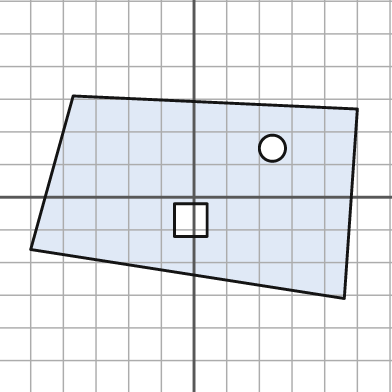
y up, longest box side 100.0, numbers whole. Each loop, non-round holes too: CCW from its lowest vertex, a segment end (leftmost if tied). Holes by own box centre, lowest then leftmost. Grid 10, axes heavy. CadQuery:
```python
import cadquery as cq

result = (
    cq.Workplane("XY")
    .moveTo(46.0, -31.0)
    .lineTo(50.0, 27.0)
    .lineTo(-37.0, 31.0)
    .lineTo(-50.0, -16.0)
    .close()
    .moveTo(-6.0, -12.0)
    .lineTo(4.0, -12.0)
    .lineTo(4.0, -2.0)
    .lineTo(-6.0, -2.0)
    .close()
    .moveTo(24.0, 15.0)
    .circle(4.0)
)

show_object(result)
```